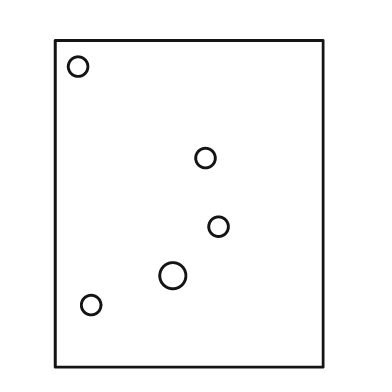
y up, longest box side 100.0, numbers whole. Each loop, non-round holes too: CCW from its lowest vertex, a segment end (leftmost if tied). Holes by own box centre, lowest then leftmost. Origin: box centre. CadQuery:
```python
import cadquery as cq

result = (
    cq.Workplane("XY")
    .moveTo(-41.0, -50.0)
    .lineTo(41.0, -50.0)
    .lineTo(41.0, 50.0)
    .lineTo(-41.0, 50.0)
    .close()
    .moveTo(-30.0, -31.0)
    .circle(3.0)
    .moveTo(-5.0, -22.0)
    .circle(4.0)
    .moveTo(9.0, -7.0)
    .circle(3.0)
    .moveTo(5.0, 14.0)
    .circle(3.0)
    .moveTo(-34.0, 42.0)
    .circle(3.0)
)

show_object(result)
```